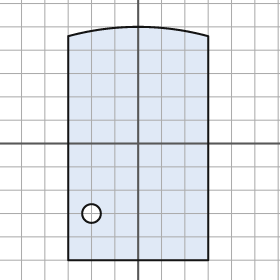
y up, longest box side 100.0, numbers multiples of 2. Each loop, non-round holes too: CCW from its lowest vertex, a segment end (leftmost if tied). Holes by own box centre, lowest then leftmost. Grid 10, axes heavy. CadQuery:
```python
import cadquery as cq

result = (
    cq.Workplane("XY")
    .moveTo(-30.0, -50.0)
    .lineTo(30.0, -50.0)
    .lineTo(30.0, 46.0)
    .threePointArc((0.0, 50.0), (-30.0, 46.0))
    .close()
    .moveTo(-20.0, -30.0)
    .circle(4.0)
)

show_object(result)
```